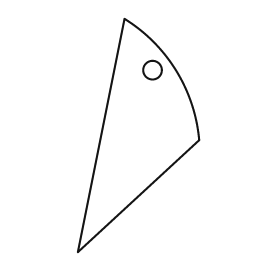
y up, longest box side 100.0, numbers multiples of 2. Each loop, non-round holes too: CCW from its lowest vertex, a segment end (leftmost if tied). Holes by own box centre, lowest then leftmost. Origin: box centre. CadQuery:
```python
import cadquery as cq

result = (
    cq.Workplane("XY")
    .moveTo(-26.0, -50.0)
    .lineTo(26.0, -2.0)
    .threePointArc((16.0, 28.0), (-6.0, 50.0))
    .close()
    .moveTo(6.0, 28.0)
    .circle(4.0)
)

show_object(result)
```